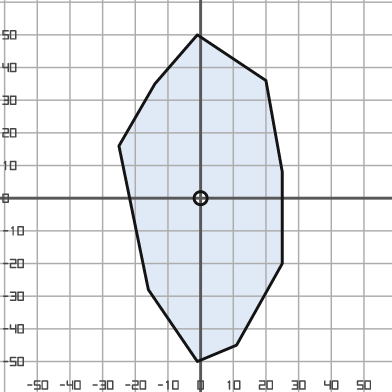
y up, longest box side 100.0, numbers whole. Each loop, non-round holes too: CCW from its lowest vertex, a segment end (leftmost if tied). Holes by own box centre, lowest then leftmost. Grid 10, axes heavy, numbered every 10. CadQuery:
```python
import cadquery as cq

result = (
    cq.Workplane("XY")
    .moveTo(-1.0, -50.0)
    .lineTo(11.0, -45.0)
    .lineTo(25.0, -20.0)
    .lineTo(25.0, 8.0)
    .lineTo(20.0, 36.0)
    .lineTo(-1.0, 50.0)
    .lineTo(-14.0, 35.0)
    .lineTo(-25.0, 16.0)
    .lineTo(-16.0, -28.0)
    .close()
    .moveTo(0.0, 0.0)
    .circle(2.0)
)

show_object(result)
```